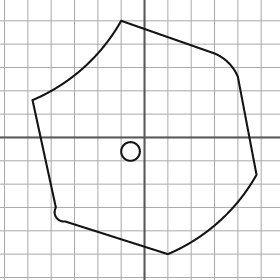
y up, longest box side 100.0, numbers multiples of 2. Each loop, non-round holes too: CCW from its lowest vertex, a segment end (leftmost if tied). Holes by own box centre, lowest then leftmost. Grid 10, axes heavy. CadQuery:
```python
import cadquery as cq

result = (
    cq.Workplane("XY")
    .moveTo(10.0, -50.0)
    .threePointArc((32.0, -36.0), (48.0, -16.0))
    .lineTo(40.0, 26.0)
    .threePointArc((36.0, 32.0), (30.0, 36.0))
    .lineTo(-10.0, 50.0)
    .threePointArc((-26.0, 30.0), (-48.0, 16.0))
    .lineTo(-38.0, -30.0)
    .threePointArc((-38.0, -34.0), (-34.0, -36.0))
    .close()
    .moveTo(-6.0, -6.0)
    .circle(4.0)
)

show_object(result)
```